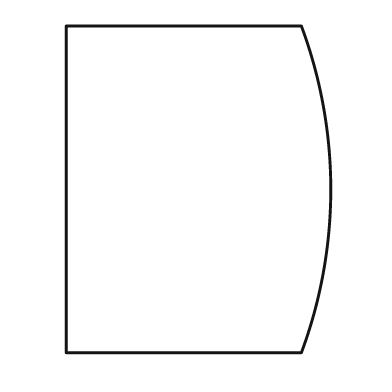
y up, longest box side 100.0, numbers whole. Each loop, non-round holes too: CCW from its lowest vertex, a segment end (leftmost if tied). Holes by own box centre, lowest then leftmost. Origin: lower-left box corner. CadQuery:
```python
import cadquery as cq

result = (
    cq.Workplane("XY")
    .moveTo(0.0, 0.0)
    .lineTo(72.0, 0.0)
    .threePointArc((81.0, 50.0), (72.0, 100.0))
    .lineTo(0.0, 100.0)
    .close()
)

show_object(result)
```